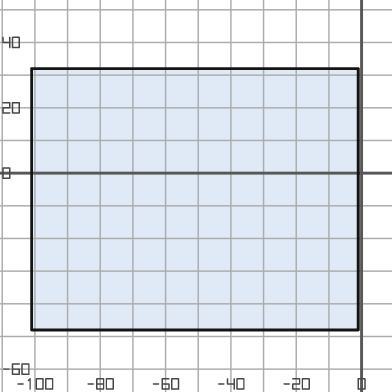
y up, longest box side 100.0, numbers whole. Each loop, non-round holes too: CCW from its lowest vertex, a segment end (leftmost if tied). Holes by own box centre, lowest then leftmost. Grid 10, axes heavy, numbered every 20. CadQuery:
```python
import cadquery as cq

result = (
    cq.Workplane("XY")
    .moveTo(-101.0, -48.0)
    .lineTo(-1.0, -48.0)
    .lineTo(-1.0, 32.0)
    .lineTo(-101.0, 32.0)
    .close()
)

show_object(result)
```